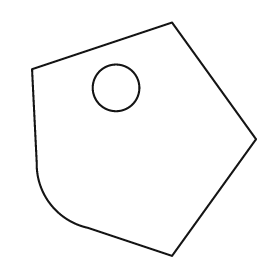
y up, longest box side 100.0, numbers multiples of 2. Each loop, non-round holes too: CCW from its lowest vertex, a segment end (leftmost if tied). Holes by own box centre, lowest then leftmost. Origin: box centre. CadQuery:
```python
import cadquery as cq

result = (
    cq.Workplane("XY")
    .moveTo(12.0, -50.0)
    .lineTo(48.0, 0.0)
    .lineTo(12.0, 50.0)
    .lineTo(-48.0, 30.0)
    .lineTo(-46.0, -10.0)
    .threePointArc((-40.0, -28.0), (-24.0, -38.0))
    .close()
    .moveTo(-12.0, 22.0)
    .circle(10.0)
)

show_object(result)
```